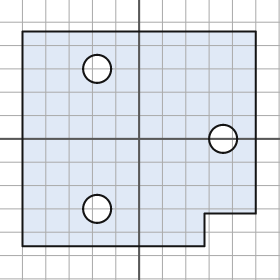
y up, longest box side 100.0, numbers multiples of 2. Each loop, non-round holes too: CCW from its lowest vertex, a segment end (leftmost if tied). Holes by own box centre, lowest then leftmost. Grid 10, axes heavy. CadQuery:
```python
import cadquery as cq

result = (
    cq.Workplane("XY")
    .moveTo(-50.0, -46.0)
    .lineTo(28.0, -46.0)
    .lineTo(28.0, -32.0)
    .lineTo(50.0, -32.0)
    .lineTo(50.0, 46.0)
    .lineTo(-50.0, 46.0)
    .close()
    .moveTo(-18.0, -30.0)
    .circle(6.0)
    .moveTo(36.0, 0.0)
    .circle(6.0)
    .moveTo(-18.0, 30.0)
    .circle(6.0)
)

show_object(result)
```